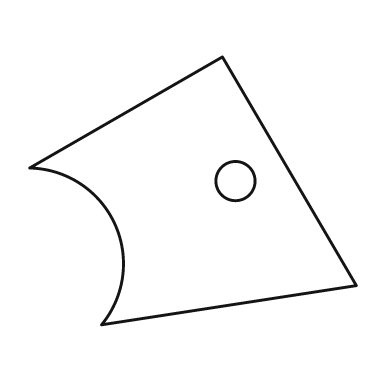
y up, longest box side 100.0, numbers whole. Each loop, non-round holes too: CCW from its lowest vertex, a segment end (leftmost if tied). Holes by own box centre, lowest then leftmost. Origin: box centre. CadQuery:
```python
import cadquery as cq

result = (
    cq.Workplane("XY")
    .moveTo(-28.0, -41.0)
    .lineTo(50.0, -29.0)
    .lineTo(9.0, 41.0)
    .lineTo(-50.0, 7.0)
    .threePointArc((-24.0, -10.0), (-28.0, -41.0))
    .close()
    .moveTo(13.0, 3.0)
    .circle(6.0)
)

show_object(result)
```